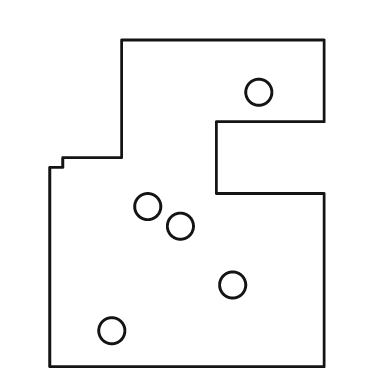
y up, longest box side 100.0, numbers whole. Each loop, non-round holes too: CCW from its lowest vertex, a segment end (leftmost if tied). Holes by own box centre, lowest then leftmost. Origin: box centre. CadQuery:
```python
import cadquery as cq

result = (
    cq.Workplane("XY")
    .moveTo(-42.0, -50.0)
    .lineTo(42.0, -50.0)
    .lineTo(42.0, 3.0)
    .lineTo(9.0, 3.0)
    .lineTo(9.0, 25.0)
    .lineTo(42.0, 25.0)
    .lineTo(42.0, 50.0)
    .lineTo(-20.0, 50.0)
    .lineTo(-20.0, 14.0)
    .lineTo(-38.0, 14.0)
    .lineTo(-38.0, 11.0)
    .lineTo(-42.0, 11.0)
    .close()
    .moveTo(-23.0, -39.0)
    .circle(4.0)
    .moveTo(14.0, -25.0)
    .circle(4.0)
    .moveTo(-2.0, -7.0)
    .circle(4.0)
    .moveTo(-12.0, -1.0)
    .circle(4.0)
    .moveTo(22.0, 34.0)
    .circle(4.0)
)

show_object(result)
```